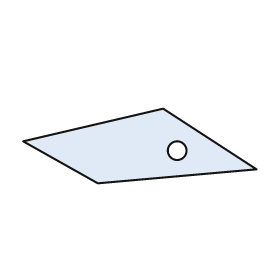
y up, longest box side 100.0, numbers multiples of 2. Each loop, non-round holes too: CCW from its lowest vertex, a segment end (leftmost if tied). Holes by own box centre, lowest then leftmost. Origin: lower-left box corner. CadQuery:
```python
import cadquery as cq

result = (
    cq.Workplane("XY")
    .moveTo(32.0, 0.0)
    .lineTo(100.0, 6.0)
    .lineTo(60.0, 32.0)
    .lineTo(0.0, 18.0)
    .close()
    .moveTo(66.0, 14.0)
    .circle(4.0)
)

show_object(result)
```